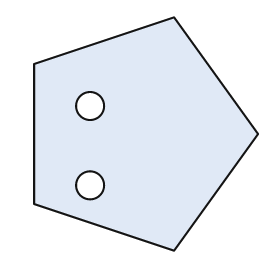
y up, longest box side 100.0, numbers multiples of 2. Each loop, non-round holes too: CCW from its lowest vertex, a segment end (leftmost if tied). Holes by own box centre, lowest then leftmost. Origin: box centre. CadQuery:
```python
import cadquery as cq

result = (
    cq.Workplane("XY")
    .moveTo(12.0, -50.0)
    .lineTo(48.0, 0.0)
    .lineTo(12.0, 50.0)
    .lineTo(-48.0, 30.0)
    .lineTo(-48.0, -30.0)
    .close()
    .moveTo(-24.0, -22.0)
    .circle(6.0)
    .moveTo(-24.0, 12.0)
    .circle(6.0)
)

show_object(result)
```